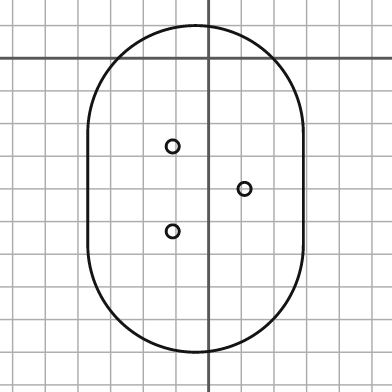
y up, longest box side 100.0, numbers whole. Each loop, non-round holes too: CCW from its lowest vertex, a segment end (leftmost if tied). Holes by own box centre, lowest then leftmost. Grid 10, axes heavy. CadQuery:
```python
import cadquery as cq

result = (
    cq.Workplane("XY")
    .moveTo(-37.0, -57.0)
    .threePointArc((-4.0, -90.0), (29.0, -57.0))
    .lineTo(29.0, -23.0)
    .threePointArc((-4.0, 10.0), (-37.0, -23.0))
    .close()
    .moveTo(-11.0, -53.0)
    .circle(2.0)
    .moveTo(11.0, -40.0)
    .circle(2.0)
    .moveTo(-11.0, -27.0)
    .circle(2.0)
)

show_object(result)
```